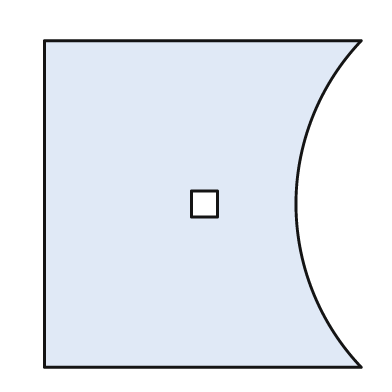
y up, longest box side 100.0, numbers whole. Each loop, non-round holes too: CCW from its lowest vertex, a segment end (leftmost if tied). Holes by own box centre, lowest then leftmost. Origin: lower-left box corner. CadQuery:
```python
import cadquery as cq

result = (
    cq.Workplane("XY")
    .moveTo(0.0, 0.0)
    .lineTo(97.0, 0.0)
    .threePointArc((77.0, 50.0), (97.0, 100.0))
    .lineTo(0.0, 100.0)
    .close()
    .moveTo(45.0, 46.0)
    .lineTo(53.0, 46.0)
    .lineTo(53.0, 54.0)
    .lineTo(45.0, 54.0)
    .close()
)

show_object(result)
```